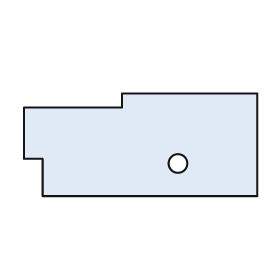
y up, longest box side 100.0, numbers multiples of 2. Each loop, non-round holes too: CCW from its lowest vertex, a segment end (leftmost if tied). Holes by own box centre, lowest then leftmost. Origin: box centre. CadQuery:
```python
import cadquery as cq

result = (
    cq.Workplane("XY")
    .moveTo(-42.0, -22.0)
    .lineTo(50.0, -22.0)
    .lineTo(50.0, 22.0)
    .lineTo(-8.0, 22.0)
    .lineTo(-8.0, 16.0)
    .lineTo(-50.0, 16.0)
    .lineTo(-50.0, -6.0)
    .lineTo(-42.0, -6.0)
    .close()
    .moveTo(16.0, -8.0)
    .circle(4.0)
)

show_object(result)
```